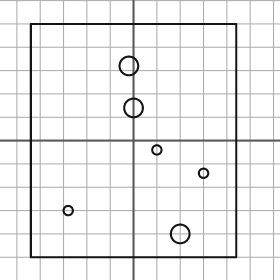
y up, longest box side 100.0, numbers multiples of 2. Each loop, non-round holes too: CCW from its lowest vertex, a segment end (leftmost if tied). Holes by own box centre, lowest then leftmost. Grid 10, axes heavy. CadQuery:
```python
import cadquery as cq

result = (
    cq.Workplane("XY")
    .moveTo(-44.0, -50.0)
    .lineTo(44.0, -50.0)
    .lineTo(44.0, 50.0)
    .lineTo(-44.0, 50.0)
    .close()
    .moveTo(20.0, -40.0)
    .circle(4.0)
    .moveTo(-28.0, -30.0)
    .circle(2.0)
    .moveTo(30.0, -14.0)
    .circle(2.0)
    .moveTo(10.0, -4.0)
    .circle(2.0)
    .moveTo(0.0, 14.0)
    .circle(4.0)
    .moveTo(-2.0, 32.0)
    .circle(4.0)
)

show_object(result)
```